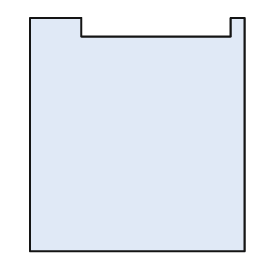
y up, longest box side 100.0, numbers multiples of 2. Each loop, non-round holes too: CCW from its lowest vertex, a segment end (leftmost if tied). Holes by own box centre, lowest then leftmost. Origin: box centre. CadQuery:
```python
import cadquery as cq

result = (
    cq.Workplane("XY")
    .moveTo(-46.0, -50.0)
    .lineTo(46.0, -50.0)
    .lineTo(46.0, 50.0)
    .lineTo(40.0, 50.0)
    .lineTo(40.0, 42.0)
    .lineTo(-24.0, 42.0)
    .lineTo(-24.0, 50.0)
    .lineTo(-46.0, 50.0)
    .close()
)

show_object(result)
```